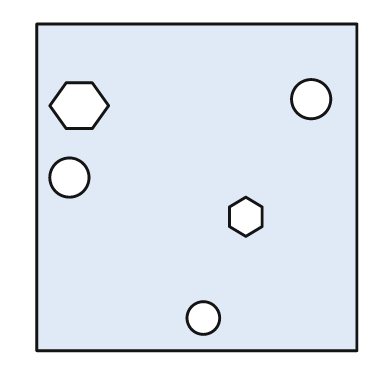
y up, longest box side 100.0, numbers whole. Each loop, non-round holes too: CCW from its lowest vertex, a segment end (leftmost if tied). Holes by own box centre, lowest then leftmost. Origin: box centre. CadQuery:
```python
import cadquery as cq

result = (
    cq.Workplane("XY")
    .moveTo(-49.0, -50.0)
    .lineTo(49.0, -50.0)
    .lineTo(49.0, 50.0)
    .lineTo(-49.0, 50.0)
    .close()
    .moveTo(2.0, -40.0)
    .circle(5.0)
    .moveTo(15.0, -15.0)
    .lineTo(20.0, -12.0)
    .lineTo(20.0, -6.0)
    .lineTo(15.0, -3.0)
    .lineTo(10.0, -6.0)
    .lineTo(10.0, -12.0)
    .close()
    .moveTo(-39.0, 3.0)
    .circle(6.0)
    .moveTo(-40.0, 18.0)
    .lineTo(-32.0, 18.0)
    .lineTo(-27.0, 25.0)
    .lineTo(-32.0, 32.0)
    .lineTo(-40.0, 32.0)
    .lineTo(-45.0, 25.0)
    .close()
    .moveTo(35.0, 27.0)
    .circle(6.0)
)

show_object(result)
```